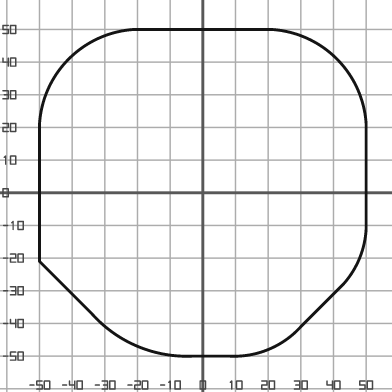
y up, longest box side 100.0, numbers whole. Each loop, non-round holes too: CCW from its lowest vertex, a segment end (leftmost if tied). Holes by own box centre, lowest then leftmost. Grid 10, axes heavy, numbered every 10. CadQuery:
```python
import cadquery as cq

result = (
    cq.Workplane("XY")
    .moveTo(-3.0, -50.0)
    .lineTo(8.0, -50.0)
    .threePointArc((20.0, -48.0), (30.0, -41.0))
    .lineTo(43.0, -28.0)
    .threePointArc((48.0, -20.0), (50.0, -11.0))
    .lineTo(50.0, 21.0)
    .threePointArc((41.0, 41.0), (21.0, 50.0))
    .lineTo(-21.0, 50.0)
    .threePointArc((-41.0, 41.0), (-50.0, 21.0))
    .lineTo(-50.0, -21.0)
    .lineTo(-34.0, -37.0)
    .threePointArc((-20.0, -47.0), (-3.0, -50.0))
    .close()
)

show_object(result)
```